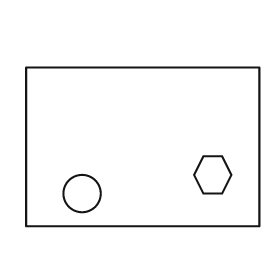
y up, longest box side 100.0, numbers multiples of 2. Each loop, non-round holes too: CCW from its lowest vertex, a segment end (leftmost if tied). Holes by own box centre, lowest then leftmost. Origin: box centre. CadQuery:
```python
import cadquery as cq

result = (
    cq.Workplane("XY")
    .moveTo(-50.0, -34.0)
    .lineTo(50.0, -34.0)
    .lineTo(50.0, 34.0)
    .lineTo(-50.0, 34.0)
    .close()
    .moveTo(-26.0, -20.0)
    .circle(8.0)
    .moveTo(26.0, -20.0)
    .lineTo(34.0, -20.0)
    .lineTo(38.0, -12.0)
    .lineTo(34.0, -4.0)
    .lineTo(26.0, -4.0)
    .lineTo(22.0, -12.0)
    .close()
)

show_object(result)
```